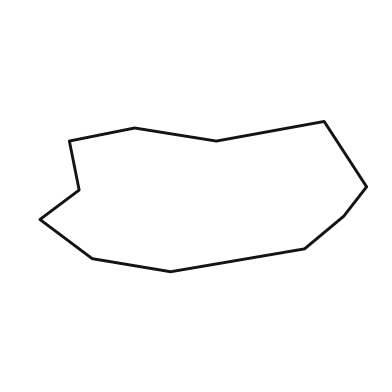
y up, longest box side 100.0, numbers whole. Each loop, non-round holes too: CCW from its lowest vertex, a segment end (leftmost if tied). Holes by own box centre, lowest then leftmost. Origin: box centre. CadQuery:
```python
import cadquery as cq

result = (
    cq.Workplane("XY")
    .moveTo(-10.0, -23.0)
    .lineTo(31.0, -16.0)
    .lineTo(43.0, -6.0)
    .lineTo(50.0, 3.0)
    .lineTo(37.0, 23.0)
    .lineTo(4.0, 17.0)
    .lineTo(-21.0, 21.0)
    .lineTo(-41.0, 17.0)
    .lineTo(-38.0, 2.0)
    .lineTo(-50.0, -7.0)
    .lineTo(-34.0, -19.0)
    .close()
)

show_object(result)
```